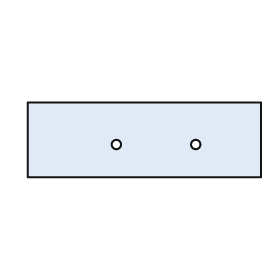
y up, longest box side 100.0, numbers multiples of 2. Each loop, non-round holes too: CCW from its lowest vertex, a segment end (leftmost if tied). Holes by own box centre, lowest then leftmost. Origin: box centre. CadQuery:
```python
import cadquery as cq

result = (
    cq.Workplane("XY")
    .moveTo(-50.0, -16.0)
    .lineTo(50.0, -16.0)
    .lineTo(50.0, 16.0)
    .lineTo(-50.0, 16.0)
    .close()
    .moveTo(-12.0, -2.0)
    .circle(2.0)
    .moveTo(22.0, -2.0)
    .circle(2.0)
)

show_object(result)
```